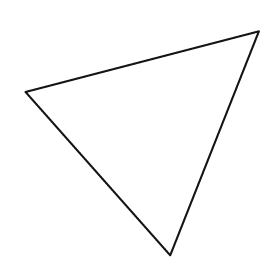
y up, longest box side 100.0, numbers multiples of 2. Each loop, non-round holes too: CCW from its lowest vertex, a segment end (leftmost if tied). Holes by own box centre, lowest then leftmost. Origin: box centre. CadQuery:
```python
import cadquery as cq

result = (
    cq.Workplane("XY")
    .moveTo(12.0, -48.0)
    .lineTo(50.0, 48.0)
    .lineTo(-50.0, 22.0)
    .close()
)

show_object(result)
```